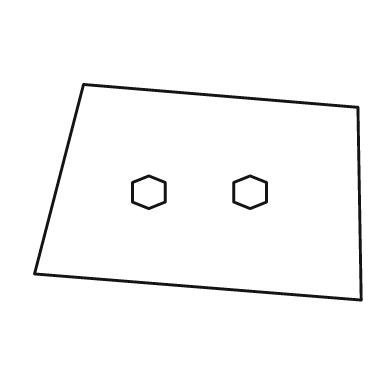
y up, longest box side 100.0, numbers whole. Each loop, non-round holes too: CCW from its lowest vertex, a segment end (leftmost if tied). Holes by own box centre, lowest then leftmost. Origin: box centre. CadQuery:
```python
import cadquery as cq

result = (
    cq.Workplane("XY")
    .moveTo(50.0, -33.0)
    .lineTo(49.0, 26.0)
    .lineTo(-35.0, 33.0)
    .lineTo(-50.0, -25.0)
    .close()
    .moveTo(-15.0, -5.0)
    .lineTo(-10.0, -3.0)
    .lineTo(-10.0, 3.0)
    .lineTo(-15.0, 5.0)
    .lineTo(-20.0, 3.0)
    .lineTo(-20.0, -3.0)
    .close()
    .moveTo(16.0, -5.0)
    .lineTo(21.0, -3.0)
    .lineTo(21.0, 3.0)
    .lineTo(16.0, 5.0)
    .lineTo(11.0, 3.0)
    .lineTo(11.0, -3.0)
    .close()
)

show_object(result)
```